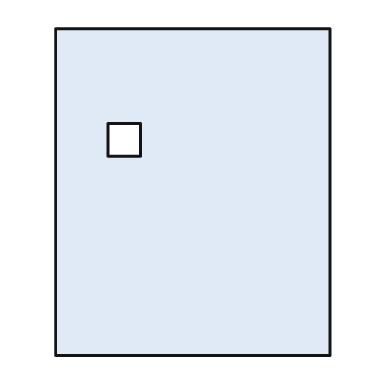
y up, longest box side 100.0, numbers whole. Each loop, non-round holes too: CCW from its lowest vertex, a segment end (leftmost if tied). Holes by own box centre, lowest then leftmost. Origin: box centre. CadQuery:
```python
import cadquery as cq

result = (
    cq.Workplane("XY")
    .moveTo(-42.0, -50.0)
    .lineTo(42.0, -50.0)
    .lineTo(42.0, 50.0)
    .lineTo(-42.0, 50.0)
    .close()
    .moveTo(-26.0, 11.0)
    .lineTo(-16.0, 11.0)
    .lineTo(-16.0, 21.0)
    .lineTo(-26.0, 21.0)
    .close()
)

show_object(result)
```